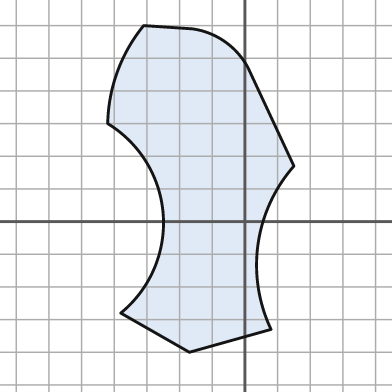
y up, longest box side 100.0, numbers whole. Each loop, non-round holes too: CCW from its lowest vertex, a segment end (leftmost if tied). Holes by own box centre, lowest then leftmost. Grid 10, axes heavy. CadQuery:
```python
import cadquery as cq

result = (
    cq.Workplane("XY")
    .moveTo(-17.0, -40.0)
    .lineTo(8.0, -33.0)
    .threePointArc((4.0, -7.0), (15.0, 17.0))
    .lineTo(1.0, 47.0)
    .threePointArc((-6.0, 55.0), (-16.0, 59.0))
    .lineTo(-31.0, 60.0)
    .threePointArc((-39.0, 46.0), (-42.0, 30.0))
    .threePointArc((-25.0, 2.0), (-38.0, -28.0))
    .close()
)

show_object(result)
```